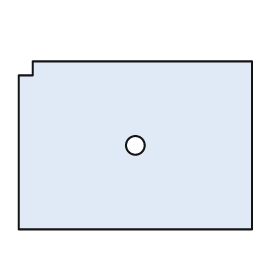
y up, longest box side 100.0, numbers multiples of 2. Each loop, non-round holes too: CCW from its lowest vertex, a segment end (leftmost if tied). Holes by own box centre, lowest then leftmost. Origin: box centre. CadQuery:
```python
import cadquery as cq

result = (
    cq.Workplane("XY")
    .moveTo(-50.0, -36.0)
    .lineTo(50.0, -36.0)
    .lineTo(50.0, 36.0)
    .lineTo(-44.0, 36.0)
    .lineTo(-44.0, 30.0)
    .lineTo(-50.0, 30.0)
    .close()
    .moveTo(0.0, 0.0)
    .circle(4.0)
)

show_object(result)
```